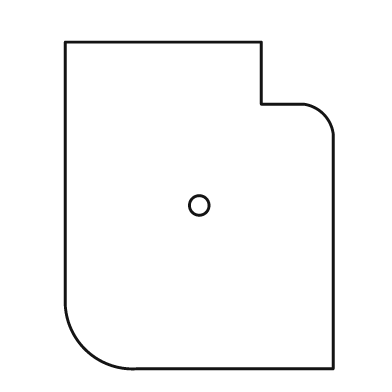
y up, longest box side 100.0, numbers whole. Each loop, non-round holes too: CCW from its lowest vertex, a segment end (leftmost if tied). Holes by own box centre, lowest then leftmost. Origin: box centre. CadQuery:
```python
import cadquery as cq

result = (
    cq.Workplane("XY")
    .moveTo(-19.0, -50.0)
    .lineTo(41.0, -50.0)
    .lineTo(41.0, 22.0)
    .threePointArc((38.0, 28.0), (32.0, 31.0))
    .lineTo(19.0, 31.0)
    .lineTo(19.0, 50.0)
    .lineTo(-41.0, 50.0)
    .lineTo(-41.0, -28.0)
    .threePointArc((-35.0, -44.0), (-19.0, -50.0))
    .close()
    .moveTo(0.0, 0.0)
    .circle(3.0)
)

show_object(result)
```